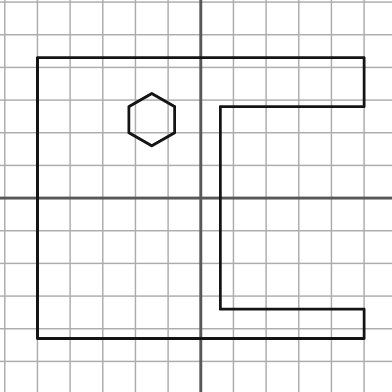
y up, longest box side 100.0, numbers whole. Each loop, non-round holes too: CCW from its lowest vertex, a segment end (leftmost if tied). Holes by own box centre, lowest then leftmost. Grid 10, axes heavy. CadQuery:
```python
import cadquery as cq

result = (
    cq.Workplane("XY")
    .moveTo(-50.0, -43.0)
    .lineTo(50.0, -43.0)
    .lineTo(50.0, -34.0)
    .lineTo(6.0, -34.0)
    .lineTo(6.0, 28.0)
    .lineTo(50.0, 28.0)
    .lineTo(50.0, 43.0)
    .lineTo(-50.0, 43.0)
    .close()
    .moveTo(-15.0, 16.0)
    .lineTo(-8.0, 20.0)
    .lineTo(-8.0, 28.0)
    .lineTo(-15.0, 32.0)
    .lineTo(-22.0, 28.0)
    .lineTo(-22.0, 20.0)
    .close()
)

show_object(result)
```